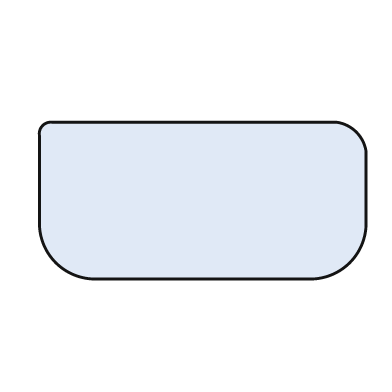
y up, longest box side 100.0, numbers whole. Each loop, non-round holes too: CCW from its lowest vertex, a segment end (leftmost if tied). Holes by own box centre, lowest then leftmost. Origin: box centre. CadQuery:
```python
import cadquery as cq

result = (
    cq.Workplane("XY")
    .moveTo(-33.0, -24.0)
    .lineTo(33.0, -24.0)
    .threePointArc((45.0, -19.0), (50.0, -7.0))
    .lineTo(50.0, 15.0)
    .threePointArc((47.0, 21.0), (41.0, 24.0))
    .lineTo(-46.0, 24.0)
    .threePointArc((-49.0, 23.0), (-50.0, 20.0))
    .lineTo(-50.0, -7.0)
    .threePointArc((-45.0, -19.0), (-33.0, -24.0))
    .close()
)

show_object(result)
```